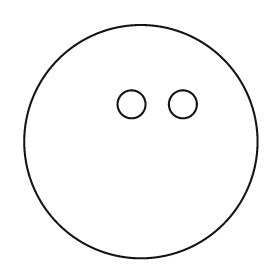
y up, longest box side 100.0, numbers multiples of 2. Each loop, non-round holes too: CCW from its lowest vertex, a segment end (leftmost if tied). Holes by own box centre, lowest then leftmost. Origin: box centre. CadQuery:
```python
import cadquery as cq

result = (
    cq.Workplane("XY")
    .moveTo(0.0, 0.0)
    .circle(50.0)
    .moveTo(-4.0, 16.0)
    .circle(6.0)
    .moveTo(18.0, 16.0)
    .circle(6.0)
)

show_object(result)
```